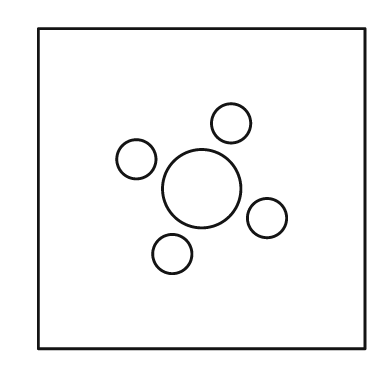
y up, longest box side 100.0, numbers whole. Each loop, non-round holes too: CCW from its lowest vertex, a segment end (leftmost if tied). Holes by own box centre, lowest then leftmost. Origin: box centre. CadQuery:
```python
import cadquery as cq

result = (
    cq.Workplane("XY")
    .moveTo(-50.0, -49.0)
    .lineTo(50.0, -49.0)
    .lineTo(50.0, 49.0)
    .lineTo(-50.0, 49.0)
    .close()
    .moveTo(-9.0, -20.0)
    .circle(6.0)
    .moveTo(20.0, -9.0)
    .circle(6.0)
    .moveTo(0.0, 0.0)
    .circle(12.0)
    .moveTo(-20.0, 9.0)
    .circle(6.0)
    .moveTo(9.0, 20.0)
    .circle(6.0)
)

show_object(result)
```